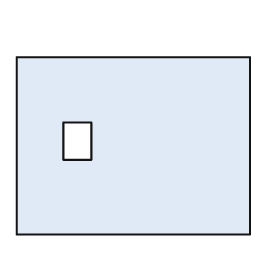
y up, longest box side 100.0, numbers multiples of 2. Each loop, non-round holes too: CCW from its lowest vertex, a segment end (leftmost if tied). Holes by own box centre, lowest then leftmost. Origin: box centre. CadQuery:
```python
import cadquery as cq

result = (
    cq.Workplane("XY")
    .moveTo(-50.0, -38.0)
    .lineTo(50.0, -38.0)
    .lineTo(50.0, 38.0)
    .lineTo(-50.0, 38.0)
    .close()
    .moveTo(-30.0, -6.0)
    .lineTo(-18.0, -6.0)
    .lineTo(-18.0, 10.0)
    .lineTo(-30.0, 10.0)
    .close()
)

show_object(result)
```